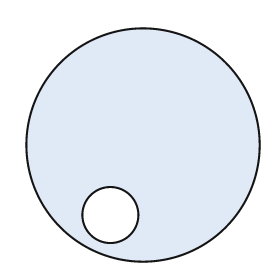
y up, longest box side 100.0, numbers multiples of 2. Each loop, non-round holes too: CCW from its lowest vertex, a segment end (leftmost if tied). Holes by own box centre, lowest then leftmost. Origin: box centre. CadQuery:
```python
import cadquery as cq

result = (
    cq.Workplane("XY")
    .moveTo(0.0, 0.0)
    .circle(50.0)
    .moveTo(-14.0, -30.0)
    .circle(12.0)
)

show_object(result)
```